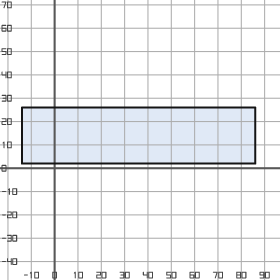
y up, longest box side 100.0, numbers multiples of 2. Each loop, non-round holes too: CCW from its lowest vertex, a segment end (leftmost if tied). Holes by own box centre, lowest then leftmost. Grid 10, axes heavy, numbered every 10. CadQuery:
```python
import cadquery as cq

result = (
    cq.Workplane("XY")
    .moveTo(-14.0, 2.0)
    .lineTo(86.0, 2.0)
    .lineTo(86.0, 26.0)
    .lineTo(-14.0, 26.0)
    .close()
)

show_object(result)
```